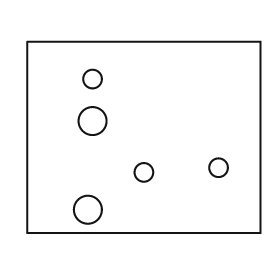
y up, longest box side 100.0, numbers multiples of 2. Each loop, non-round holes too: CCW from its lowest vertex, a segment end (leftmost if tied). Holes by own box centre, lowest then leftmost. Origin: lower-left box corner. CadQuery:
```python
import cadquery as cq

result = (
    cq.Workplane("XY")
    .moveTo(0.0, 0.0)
    .lineTo(100.0, 0.0)
    .lineTo(100.0, 82.0)
    .lineTo(0.0, 82.0)
    .close()
    .moveTo(26.0, 10.0)
    .circle(6.0)
    .moveTo(50.0, 26.0)
    .circle(4.0)
    .moveTo(82.0, 28.0)
    .circle(4.0)
    .moveTo(28.0, 48.0)
    .circle(6.0)
    .moveTo(28.0, 66.0)
    .circle(4.0)
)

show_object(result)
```